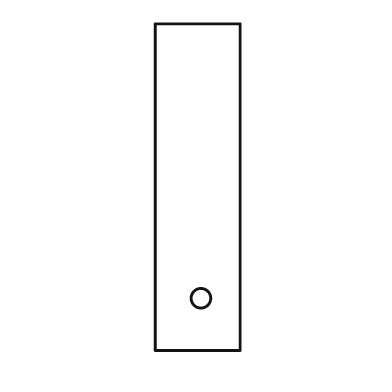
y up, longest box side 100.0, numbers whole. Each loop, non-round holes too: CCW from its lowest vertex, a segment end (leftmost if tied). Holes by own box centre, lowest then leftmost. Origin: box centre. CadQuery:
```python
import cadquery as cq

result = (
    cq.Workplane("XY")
    .moveTo(-13.0, -50.0)
    .lineTo(13.0, -50.0)
    .lineTo(13.0, 50.0)
    .lineTo(-13.0, 50.0)
    .close()
    .moveTo(1.0, -34.0)
    .circle(3.0)
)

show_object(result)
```